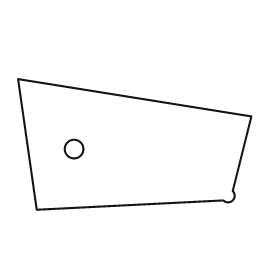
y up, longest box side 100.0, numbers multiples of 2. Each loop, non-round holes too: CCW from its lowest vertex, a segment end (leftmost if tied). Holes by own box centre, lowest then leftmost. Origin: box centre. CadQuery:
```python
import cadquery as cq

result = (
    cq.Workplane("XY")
    .moveTo(-42.0, -28.0)
    .lineTo(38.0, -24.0)
    .threePointArc((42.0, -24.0), (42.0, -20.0))
    .lineTo(50.0, 12.0)
    .lineTo(-50.0, 28.0)
    .close()
    .moveTo(-26.0, -2.0)
    .circle(4.0)
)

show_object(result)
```